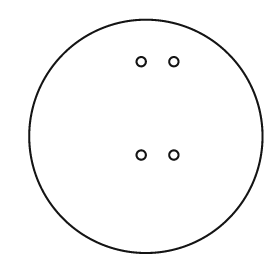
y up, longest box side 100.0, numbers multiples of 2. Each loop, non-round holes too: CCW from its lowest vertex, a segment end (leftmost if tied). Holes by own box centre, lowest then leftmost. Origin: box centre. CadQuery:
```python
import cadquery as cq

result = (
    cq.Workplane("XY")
    .moveTo(0.0, 0.0)
    .circle(50.0)
    .moveTo(-2.0, -8.0)
    .circle(2.0)
    .moveTo(12.0, -8.0)
    .circle(2.0)
    .moveTo(-2.0, 32.0)
    .circle(2.0)
    .moveTo(12.0, 32.0)
    .circle(2.0)
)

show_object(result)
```